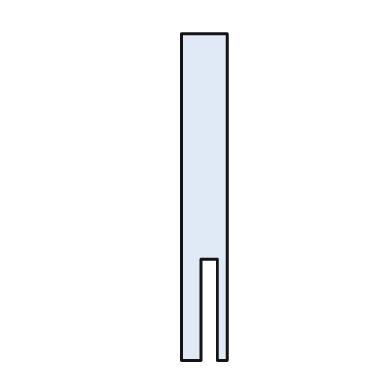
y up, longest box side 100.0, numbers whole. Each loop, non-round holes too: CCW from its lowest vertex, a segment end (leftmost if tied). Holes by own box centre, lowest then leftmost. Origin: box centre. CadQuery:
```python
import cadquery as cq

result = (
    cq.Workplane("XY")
    .moveTo(-7.0, -50.0)
    .lineTo(-1.0, -50.0)
    .lineTo(-1.0, -19.0)
    .lineTo(4.0, -19.0)
    .lineTo(4.0, -50.0)
    .lineTo(7.0, -50.0)
    .lineTo(7.0, 50.0)
    .lineTo(-7.0, 50.0)
    .close()
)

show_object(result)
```